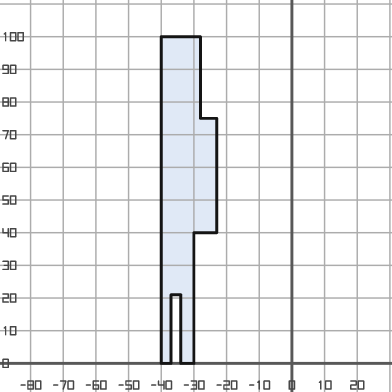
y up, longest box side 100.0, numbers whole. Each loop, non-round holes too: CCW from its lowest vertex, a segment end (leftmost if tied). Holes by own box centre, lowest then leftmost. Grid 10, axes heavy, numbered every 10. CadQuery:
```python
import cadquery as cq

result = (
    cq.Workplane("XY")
    .moveTo(-40.0, 0.0)
    .lineTo(-37.0, 0.0)
    .lineTo(-37.0, 21.0)
    .lineTo(-34.0, 21.0)
    .lineTo(-34.0, 0.0)
    .lineTo(-30.0, 0.0)
    .lineTo(-30.0, 40.0)
    .lineTo(-23.0, 40.0)
    .lineTo(-23.0, 75.0)
    .lineTo(-28.0, 75.0)
    .lineTo(-28.0, 100.0)
    .lineTo(-40.0, 100.0)
    .close()
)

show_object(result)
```